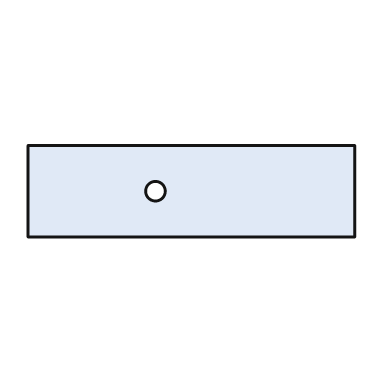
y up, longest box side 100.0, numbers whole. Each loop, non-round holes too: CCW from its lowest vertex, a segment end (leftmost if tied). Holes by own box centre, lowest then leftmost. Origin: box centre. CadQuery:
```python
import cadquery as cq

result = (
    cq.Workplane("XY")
    .moveTo(-50.0, -14.0)
    .lineTo(50.0, -14.0)
    .lineTo(50.0, 14.0)
    .lineTo(-50.0, 14.0)
    .close()
    .moveTo(-11.0, 0.0)
    .circle(3.0)
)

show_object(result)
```